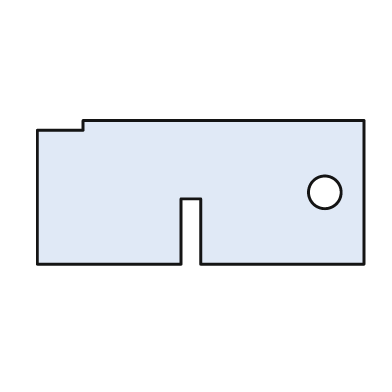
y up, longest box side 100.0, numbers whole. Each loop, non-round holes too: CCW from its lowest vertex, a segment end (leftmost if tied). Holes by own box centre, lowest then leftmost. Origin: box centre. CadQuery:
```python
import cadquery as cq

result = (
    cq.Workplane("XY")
    .moveTo(-50.0, -22.0)
    .lineTo(-6.0, -22.0)
    .lineTo(-6.0, -2.0)
    .lineTo(0.0, -2.0)
    .lineTo(0.0, -22.0)
    .lineTo(50.0, -22.0)
    .lineTo(50.0, 22.0)
    .lineTo(-36.0, 22.0)
    .lineTo(-36.0, 19.0)
    .lineTo(-50.0, 19.0)
    .close()
    .moveTo(38.0, 0.0)
    .circle(5.0)
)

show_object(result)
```